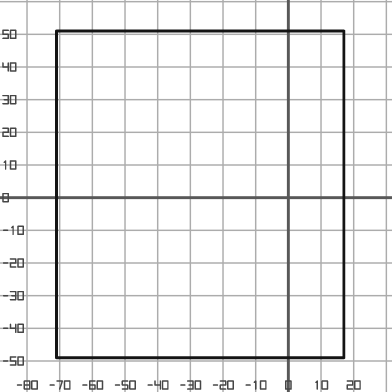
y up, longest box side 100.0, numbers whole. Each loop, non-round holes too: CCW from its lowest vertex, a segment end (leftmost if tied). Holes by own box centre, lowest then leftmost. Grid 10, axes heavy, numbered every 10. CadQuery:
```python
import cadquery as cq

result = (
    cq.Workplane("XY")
    .moveTo(-71.0, -49.0)
    .lineTo(17.0, -49.0)
    .lineTo(17.0, 51.0)
    .lineTo(-71.0, 51.0)
    .close()
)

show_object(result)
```